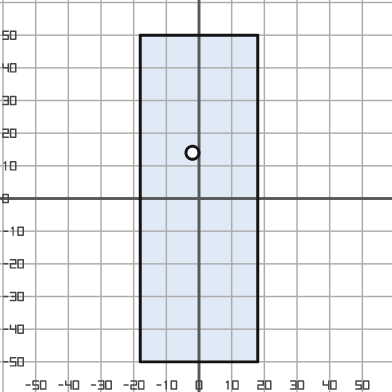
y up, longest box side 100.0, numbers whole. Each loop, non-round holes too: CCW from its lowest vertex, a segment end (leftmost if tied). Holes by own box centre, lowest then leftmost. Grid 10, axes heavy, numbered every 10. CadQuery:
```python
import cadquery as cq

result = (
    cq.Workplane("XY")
    .moveTo(-18.0, -50.0)
    .lineTo(18.0, -50.0)
    .lineTo(18.0, 50.0)
    .lineTo(-18.0, 50.0)
    .close()
    .moveTo(-2.0, 14.0)
    .circle(2.0)
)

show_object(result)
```